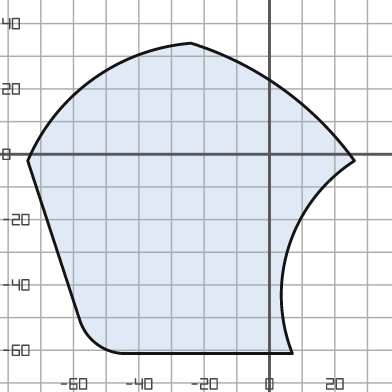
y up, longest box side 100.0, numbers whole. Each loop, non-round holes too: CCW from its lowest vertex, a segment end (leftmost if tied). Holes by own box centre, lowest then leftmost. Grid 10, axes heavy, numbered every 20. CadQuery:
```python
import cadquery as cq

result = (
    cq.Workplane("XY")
    .moveTo(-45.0, -61.0)
    .lineTo(7.0, -61.0)
    .threePointArc((6.0, -28.0), (26.0, -2.0))
    .threePointArc((4.0, 20.0), (-24.0, 34.0))
    .threePointArc((-54.0, 23.0), (-74.0, -2.0))
    .lineTo(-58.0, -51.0)
    .threePointArc((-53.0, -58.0), (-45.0, -61.0))
    .close()
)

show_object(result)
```